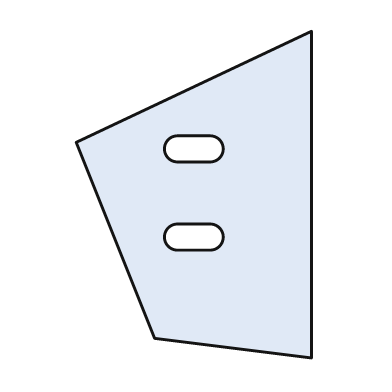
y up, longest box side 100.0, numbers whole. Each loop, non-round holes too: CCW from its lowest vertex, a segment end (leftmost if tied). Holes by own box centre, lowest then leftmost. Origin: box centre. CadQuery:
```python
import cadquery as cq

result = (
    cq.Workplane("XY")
    .moveTo(36.0, -50.0)
    .lineTo(36.0, 50.0)
    .lineTo(-36.0, 16.0)
    .lineTo(-12.0, -44.0)
    .close()
    .moveTo(-5.0, -17.0)
    .lineTo(5.0, -17.0)
    .threePointArc((9.0, -13.0), (5.0, -9.0))
    .lineTo(-5.0, -9.0)
    .threePointArc((-9.0, -13.0), (-5.0, -17.0))
    .close()
    .moveTo(-5.0, 10.0)
    .lineTo(5.0, 10.0)
    .threePointArc((9.0, 14.0), (5.0, 18.0))
    .lineTo(-5.0, 18.0)
    .threePointArc((-9.0, 14.0), (-5.0, 10.0))
    .close()
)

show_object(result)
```